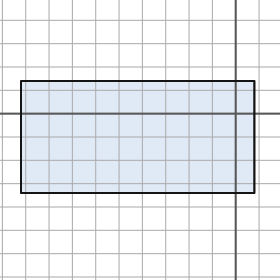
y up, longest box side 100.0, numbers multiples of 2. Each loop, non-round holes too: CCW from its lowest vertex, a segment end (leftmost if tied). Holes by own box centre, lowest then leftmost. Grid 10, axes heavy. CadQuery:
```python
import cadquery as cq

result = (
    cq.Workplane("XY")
    .moveTo(-92.0, -34.0)
    .lineTo(8.0, -34.0)
    .lineTo(8.0, 14.0)
    .lineTo(-92.0, 14.0)
    .close()
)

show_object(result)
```